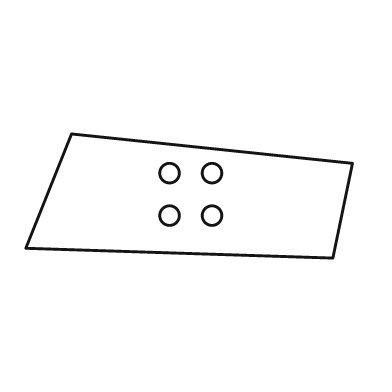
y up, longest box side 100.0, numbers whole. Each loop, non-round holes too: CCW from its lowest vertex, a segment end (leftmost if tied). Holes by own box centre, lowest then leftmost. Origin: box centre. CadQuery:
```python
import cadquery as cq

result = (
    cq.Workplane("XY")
    .moveTo(44.0, -19.0)
    .lineTo(50.0, 10.0)
    .lineTo(-36.0, 19.0)
    .lineTo(-50.0, -16.0)
    .close()
    .moveTo(-6.0, -6.0)
    .circle(3.0)
    .moveTo(7.0, -6.0)
    .circle(3.0)
    .moveTo(-6.0, 7.0)
    .circle(3.0)
    .moveTo(7.0, 7.0)
    .circle(3.0)
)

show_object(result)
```